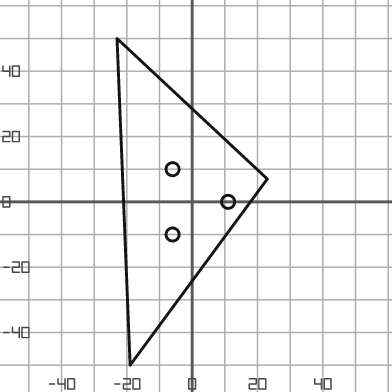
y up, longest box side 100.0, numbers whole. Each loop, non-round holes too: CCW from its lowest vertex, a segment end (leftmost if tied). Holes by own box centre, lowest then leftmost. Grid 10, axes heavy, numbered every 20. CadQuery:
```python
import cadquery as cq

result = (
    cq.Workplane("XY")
    .moveTo(-19.0, -50.0)
    .lineTo(23.0, 7.0)
    .lineTo(-23.0, 50.0)
    .close()
    .moveTo(-6.0, -10.0)
    .circle(2.0)
    .moveTo(11.0, 0.0)
    .circle(2.0)
    .moveTo(-6.0, 10.0)
    .circle(2.0)
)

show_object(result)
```